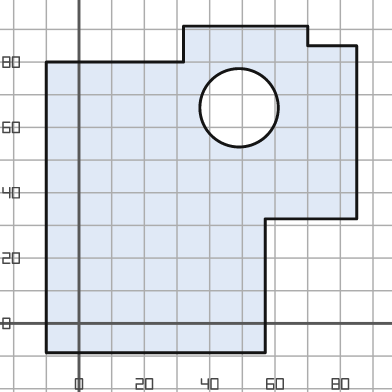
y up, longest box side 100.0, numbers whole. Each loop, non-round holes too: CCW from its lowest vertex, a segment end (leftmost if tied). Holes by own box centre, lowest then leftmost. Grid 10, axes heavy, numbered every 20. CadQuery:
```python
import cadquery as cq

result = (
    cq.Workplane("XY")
    .moveTo(-10.0, -9.0)
    .lineTo(57.0, -9.0)
    .lineTo(57.0, 32.0)
    .lineTo(85.0, 32.0)
    .lineTo(85.0, 85.0)
    .lineTo(70.0, 85.0)
    .lineTo(70.0, 91.0)
    .lineTo(32.0, 91.0)
    .lineTo(32.0, 80.0)
    .lineTo(-10.0, 80.0)
    .close()
    .moveTo(49.0, 66.0)
    .circle(12.0)
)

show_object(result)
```